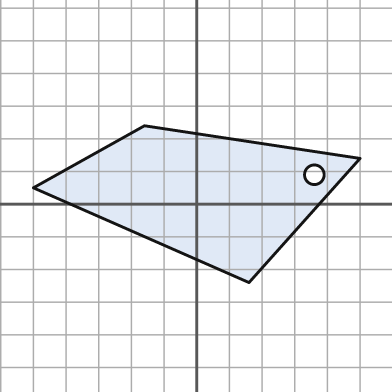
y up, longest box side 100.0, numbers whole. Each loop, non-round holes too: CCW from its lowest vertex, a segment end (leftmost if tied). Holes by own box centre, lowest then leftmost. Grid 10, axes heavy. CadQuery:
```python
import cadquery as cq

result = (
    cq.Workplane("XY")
    .moveTo(16.0, -24.0)
    .lineTo(50.0, 14.0)
    .lineTo(-16.0, 24.0)
    .lineTo(-50.0, 5.0)
    .close()
    .moveTo(36.0, 9.0)
    .circle(3.0)
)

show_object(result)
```